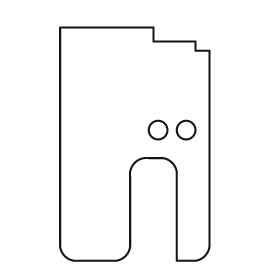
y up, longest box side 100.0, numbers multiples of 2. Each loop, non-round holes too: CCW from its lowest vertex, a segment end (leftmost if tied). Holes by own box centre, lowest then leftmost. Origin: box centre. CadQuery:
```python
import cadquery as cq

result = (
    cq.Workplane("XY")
    .moveTo(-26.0, -50.0)
    .lineTo(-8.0, -50.0)
    .threePointArc((-4.0, -48.0), (-2.0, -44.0))
    .lineTo(-2.0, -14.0)
    .threePointArc((0.0, -8.0), (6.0, -6.0))
    .lineTo(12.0, -6.0)
    .threePointArc((16.0, -8.0), (18.0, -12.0))
    .lineTo(18.0, -50.0)
    .lineTo(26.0, -50.0)
    .threePointArc((30.0, -48.0), (32.0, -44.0))
    .lineTo(32.0, 40.0)
    .lineTo(26.0, 40.0)
    .lineTo(26.0, 44.0)
    .lineTo(8.0, 44.0)
    .lineTo(8.0, 50.0)
    .lineTo(-32.0, 50.0)
    .lineTo(-32.0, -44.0)
    .threePointArc((-30.0, -48.0), (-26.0, -50.0))
    .close()
    .moveTo(10.0, 6.0)
    .circle(4.0)
    .moveTo(22.0, 6.0)
    .circle(4.0)
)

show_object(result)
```